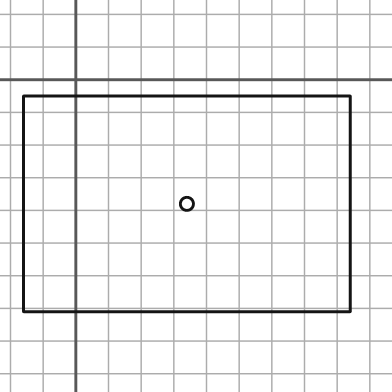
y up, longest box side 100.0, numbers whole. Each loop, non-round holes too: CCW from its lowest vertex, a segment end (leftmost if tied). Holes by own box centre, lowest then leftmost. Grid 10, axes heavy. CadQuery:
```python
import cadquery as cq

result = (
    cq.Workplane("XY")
    .moveTo(-16.0, -71.0)
    .lineTo(84.0, -71.0)
    .lineTo(84.0, -5.0)
    .lineTo(-16.0, -5.0)
    .close()
    .moveTo(34.0, -38.0)
    .circle(2.0)
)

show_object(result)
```